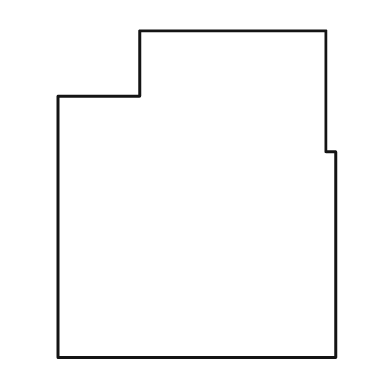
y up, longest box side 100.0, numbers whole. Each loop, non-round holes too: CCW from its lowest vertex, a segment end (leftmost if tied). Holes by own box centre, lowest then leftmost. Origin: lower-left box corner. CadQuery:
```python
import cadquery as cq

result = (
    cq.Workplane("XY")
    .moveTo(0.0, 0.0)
    .lineTo(85.0, 0.0)
    .lineTo(85.0, 63.0)
    .lineTo(82.0, 63.0)
    .lineTo(82.0, 100.0)
    .lineTo(25.0, 100.0)
    .lineTo(25.0, 80.0)
    .lineTo(0.0, 80.0)
    .close()
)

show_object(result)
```